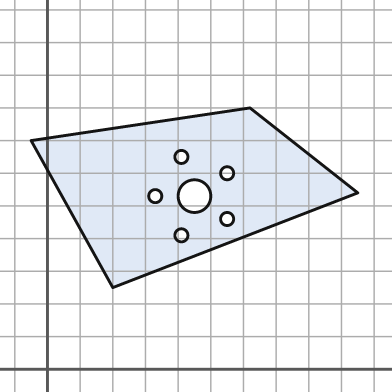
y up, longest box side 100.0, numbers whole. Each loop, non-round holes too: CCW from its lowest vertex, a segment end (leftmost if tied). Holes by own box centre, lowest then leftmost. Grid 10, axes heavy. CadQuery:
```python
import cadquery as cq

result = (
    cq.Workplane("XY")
    .moveTo(20.0, 25.0)
    .lineTo(95.0, 54.0)
    .lineTo(62.0, 80.0)
    .lineTo(-5.0, 70.0)
    .close()
    .moveTo(41.0, 41.0)
    .circle(2.0)
    .moveTo(55.0, 46.0)
    .circle(2.0)
    .moveTo(33.0, 53.0)
    .circle(2.0)
    .moveTo(45.0, 53.0)
    .circle(5.0)
    .moveTo(55.0, 60.0)
    .circle(2.0)
    .moveTo(41.0, 65.0)
    .circle(2.0)
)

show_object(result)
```